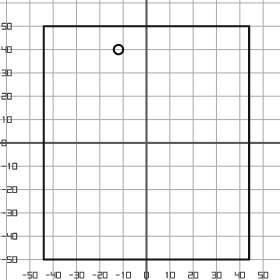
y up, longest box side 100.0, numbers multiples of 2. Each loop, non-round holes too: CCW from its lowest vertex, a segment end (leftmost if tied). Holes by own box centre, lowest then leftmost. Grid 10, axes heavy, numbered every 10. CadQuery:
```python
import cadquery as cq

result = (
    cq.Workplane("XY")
    .moveTo(-44.0, -50.0)
    .lineTo(44.0, -50.0)
    .lineTo(44.0, 50.0)
    .lineTo(-44.0, 50.0)
    .close()
    .moveTo(-12.0, 40.0)
    .circle(2.0)
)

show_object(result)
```